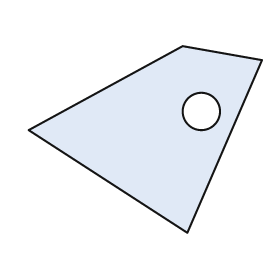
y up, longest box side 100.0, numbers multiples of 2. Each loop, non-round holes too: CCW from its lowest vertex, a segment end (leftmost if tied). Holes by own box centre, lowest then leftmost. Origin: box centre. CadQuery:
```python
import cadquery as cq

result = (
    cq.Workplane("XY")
    .moveTo(18.0, -40.0)
    .lineTo(50.0, 34.0)
    .lineTo(16.0, 40.0)
    .lineTo(-50.0, 4.0)
    .close()
    .moveTo(24.0, 12.0)
    .circle(8.0)
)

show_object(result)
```